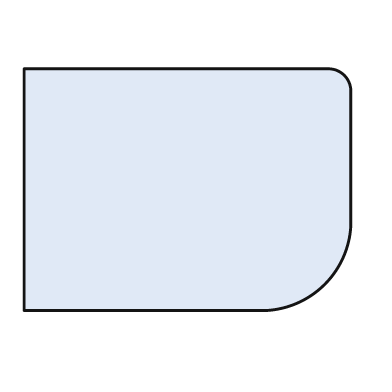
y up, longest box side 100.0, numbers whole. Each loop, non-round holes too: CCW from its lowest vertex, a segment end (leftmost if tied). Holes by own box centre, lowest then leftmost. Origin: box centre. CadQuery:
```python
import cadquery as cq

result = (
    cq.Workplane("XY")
    .moveTo(-50.0, -37.0)
    .lineTo(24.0, -37.0)
    .threePointArc((42.0, -29.0), (50.0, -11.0))
    .lineTo(50.0, 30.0)
    .threePointArc((48.0, 35.0), (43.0, 37.0))
    .lineTo(-50.0, 37.0)
    .close()
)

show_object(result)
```